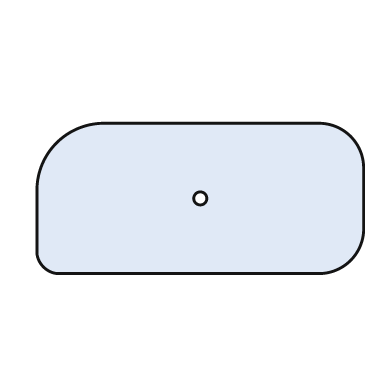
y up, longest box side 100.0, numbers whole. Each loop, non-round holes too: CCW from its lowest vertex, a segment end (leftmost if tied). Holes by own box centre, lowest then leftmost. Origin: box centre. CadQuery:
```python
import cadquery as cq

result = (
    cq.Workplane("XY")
    .moveTo(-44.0, -23.0)
    .lineTo(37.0, -23.0)
    .threePointArc((46.0, -19.0), (50.0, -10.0))
    .lineTo(50.0, 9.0)
    .threePointArc((46.0, 19.0), (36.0, 23.0))
    .lineTo(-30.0, 23.0)
    .threePointArc((-44.0, 17.0), (-50.0, 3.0))
    .lineTo(-50.0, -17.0)
    .threePointArc((-48.0, -21.0), (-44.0, -23.0))
    .close()
    .moveTo(0.0, 0.0)
    .circle(2.0)
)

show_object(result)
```